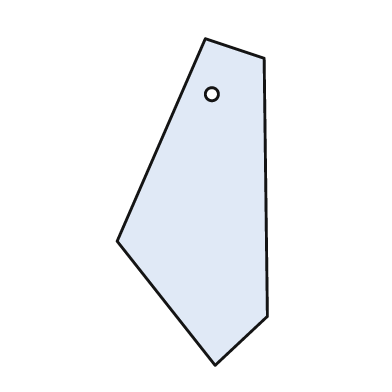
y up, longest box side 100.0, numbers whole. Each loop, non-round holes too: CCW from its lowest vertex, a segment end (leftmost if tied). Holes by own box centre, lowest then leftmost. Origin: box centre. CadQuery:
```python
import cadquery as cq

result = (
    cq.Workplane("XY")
    .moveTo(7.0, -50.0)
    .lineTo(23.0, -35.0)
    .lineTo(22.0, 44.0)
    .lineTo(4.0, 50.0)
    .lineTo(-23.0, -12.0)
    .close()
    .moveTo(6.0, 33.0)
    .circle(2.0)
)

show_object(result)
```